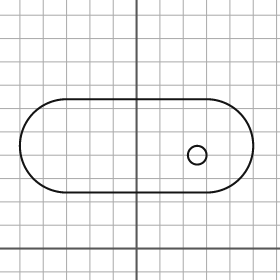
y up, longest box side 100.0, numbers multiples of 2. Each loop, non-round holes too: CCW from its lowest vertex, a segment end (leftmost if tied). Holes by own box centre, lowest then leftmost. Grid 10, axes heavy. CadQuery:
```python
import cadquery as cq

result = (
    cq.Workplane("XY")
    .moveTo(-30.0, 24.0)
    .lineTo(30.0, 24.0)
    .threePointArc((50.0, 44.0), (30.0, 64.0))
    .lineTo(-30.0, 64.0)
    .threePointArc((-50.0, 44.0), (-30.0, 24.0))
    .close()
    .moveTo(26.0, 40.0)
    .circle(4.0)
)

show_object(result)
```